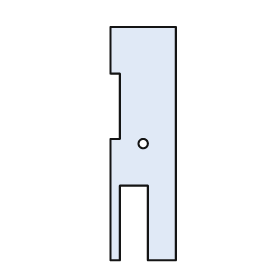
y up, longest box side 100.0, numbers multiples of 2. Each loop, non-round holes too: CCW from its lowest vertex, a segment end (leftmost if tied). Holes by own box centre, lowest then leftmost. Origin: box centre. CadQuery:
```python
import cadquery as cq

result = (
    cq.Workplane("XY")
    .moveTo(-14.0, -50.0)
    .lineTo(-10.0, -50.0)
    .lineTo(-10.0, -18.0)
    .lineTo(2.0, -18.0)
    .lineTo(2.0, -50.0)
    .lineTo(14.0, -50.0)
    .lineTo(14.0, 50.0)
    .lineTo(-14.0, 50.0)
    .lineTo(-14.0, 30.0)
    .lineTo(-10.0, 30.0)
    .lineTo(-10.0, 2.0)
    .lineTo(-14.0, 2.0)
    .close()
    .moveTo(0.0, 0.0)
    .circle(2.0)
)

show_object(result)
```